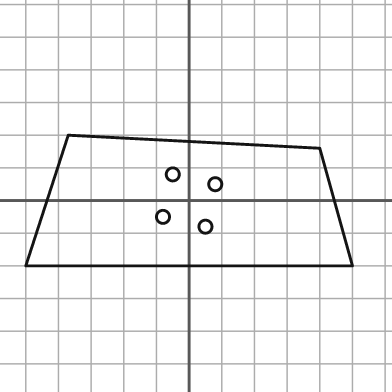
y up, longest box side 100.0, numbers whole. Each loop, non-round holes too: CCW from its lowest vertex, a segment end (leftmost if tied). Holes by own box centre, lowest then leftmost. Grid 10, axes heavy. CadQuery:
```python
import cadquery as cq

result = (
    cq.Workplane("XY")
    .moveTo(-50.0, -20.0)
    .lineTo(50.0, -20.0)
    .lineTo(40.0, 16.0)
    .lineTo(-37.0, 20.0)
    .close()
    .moveTo(5.0, -8.0)
    .circle(2.0)
    .moveTo(-8.0, -5.0)
    .circle(2.0)
    .moveTo(8.0, 5.0)
    .circle(2.0)
    .moveTo(-5.0, 8.0)
    .circle(2.0)
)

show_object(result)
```